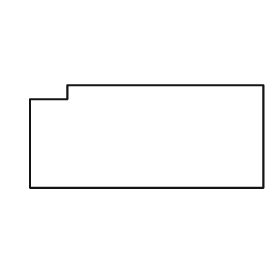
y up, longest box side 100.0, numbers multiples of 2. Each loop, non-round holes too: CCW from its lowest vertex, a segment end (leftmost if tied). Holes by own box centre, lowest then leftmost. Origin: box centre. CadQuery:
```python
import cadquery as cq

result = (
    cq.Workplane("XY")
    .moveTo(-50.0, -22.0)
    .lineTo(50.0, -22.0)
    .lineTo(50.0, 22.0)
    .lineTo(-34.0, 22.0)
    .lineTo(-34.0, 16.0)
    .lineTo(-50.0, 16.0)
    .close()
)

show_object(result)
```